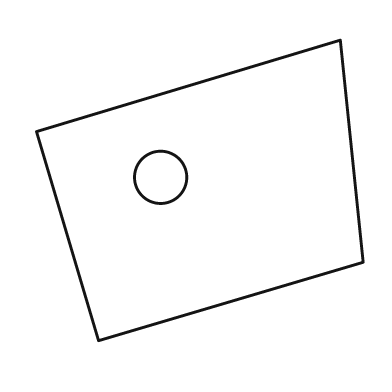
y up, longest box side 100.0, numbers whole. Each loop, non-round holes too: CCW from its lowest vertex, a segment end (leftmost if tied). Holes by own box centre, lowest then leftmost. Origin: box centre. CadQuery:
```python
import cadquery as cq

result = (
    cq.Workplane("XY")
    .moveTo(-31.0, -46.0)
    .lineTo(50.0, -22.0)
    .lineTo(43.0, 46.0)
    .lineTo(-50.0, 18.0)
    .close()
    .moveTo(-12.0, 4.0)
    .circle(8.0)
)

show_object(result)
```